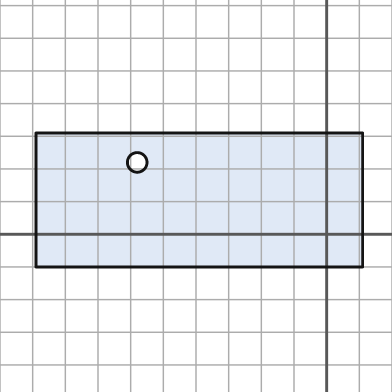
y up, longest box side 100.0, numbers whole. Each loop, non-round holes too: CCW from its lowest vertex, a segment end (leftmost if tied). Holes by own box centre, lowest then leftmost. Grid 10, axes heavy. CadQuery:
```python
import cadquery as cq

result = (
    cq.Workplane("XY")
    .moveTo(-89.0, -10.0)
    .lineTo(11.0, -10.0)
    .lineTo(11.0, 31.0)
    .lineTo(-89.0, 31.0)
    .close()
    .moveTo(-58.0, 22.0)
    .circle(3.0)
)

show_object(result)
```